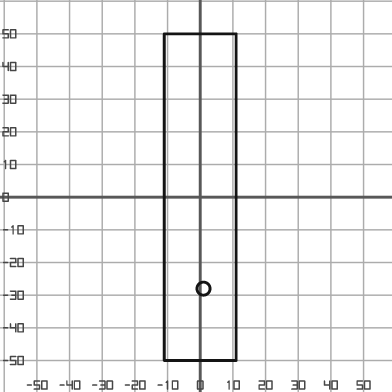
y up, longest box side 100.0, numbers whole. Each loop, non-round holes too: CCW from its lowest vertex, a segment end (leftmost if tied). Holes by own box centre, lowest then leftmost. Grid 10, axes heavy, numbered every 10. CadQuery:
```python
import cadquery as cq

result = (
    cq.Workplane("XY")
    .moveTo(-11.0, -50.0)
    .lineTo(11.0, -50.0)
    .lineTo(11.0, 50.0)
    .lineTo(-11.0, 50.0)
    .close()
    .moveTo(1.0, -28.0)
    .circle(2.0)
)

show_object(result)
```